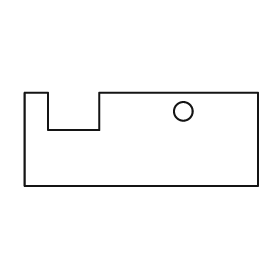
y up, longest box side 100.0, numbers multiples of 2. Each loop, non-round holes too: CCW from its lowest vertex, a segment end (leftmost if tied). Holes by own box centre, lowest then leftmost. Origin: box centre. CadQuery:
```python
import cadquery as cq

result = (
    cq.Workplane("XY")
    .moveTo(-50.0, -20.0)
    .lineTo(50.0, -20.0)
    .lineTo(50.0, 20.0)
    .lineTo(-18.0, 20.0)
    .lineTo(-18.0, 4.0)
    .lineTo(-40.0, 4.0)
    .lineTo(-40.0, 20.0)
    .lineTo(-50.0, 20.0)
    .close()
    .moveTo(18.0, 12.0)
    .circle(4.0)
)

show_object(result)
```